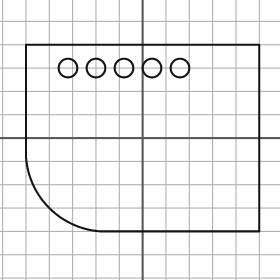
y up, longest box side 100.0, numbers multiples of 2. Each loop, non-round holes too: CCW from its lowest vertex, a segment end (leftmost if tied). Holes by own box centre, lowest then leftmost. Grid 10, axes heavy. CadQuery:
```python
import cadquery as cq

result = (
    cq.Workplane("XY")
    .moveTo(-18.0, -40.0)
    .lineTo(50.0, -40.0)
    .lineTo(50.0, 40.0)
    .lineTo(-50.0, 40.0)
    .lineTo(-50.0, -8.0)
    .threePointArc((-40.0, -30.0), (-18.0, -40.0))
    .close()
    .moveTo(-32.0, 30.0)
    .circle(4.0)
    .moveTo(-20.0, 30.0)
    .circle(4.0)
    .moveTo(-8.0, 30.0)
    .circle(4.0)
    .moveTo(4.0, 30.0)
    .circle(4.0)
    .moveTo(16.0, 30.0)
    .circle(4.0)
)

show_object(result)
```